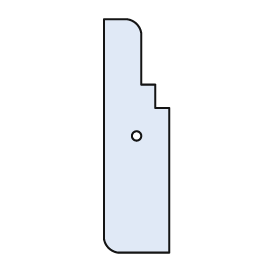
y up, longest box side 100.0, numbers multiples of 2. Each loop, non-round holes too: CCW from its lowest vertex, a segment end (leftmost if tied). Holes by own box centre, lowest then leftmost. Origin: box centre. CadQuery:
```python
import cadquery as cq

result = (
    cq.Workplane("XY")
    .moveTo(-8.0, -50.0)
    .lineTo(14.0, -50.0)
    .lineTo(14.0, 12.0)
    .lineTo(8.0, 12.0)
    .lineTo(8.0, 22.0)
    .lineTo(2.0, 22.0)
    .lineTo(2.0, 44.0)
    .threePointArc((0.0, 48.0), (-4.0, 50.0))
    .lineTo(-14.0, 50.0)
    .lineTo(-14.0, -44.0)
    .threePointArc((-12.0, -48.0), (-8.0, -50.0))
    .close()
    .moveTo(0.0, 0.0)
    .circle(2.0)
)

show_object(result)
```